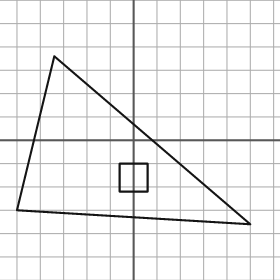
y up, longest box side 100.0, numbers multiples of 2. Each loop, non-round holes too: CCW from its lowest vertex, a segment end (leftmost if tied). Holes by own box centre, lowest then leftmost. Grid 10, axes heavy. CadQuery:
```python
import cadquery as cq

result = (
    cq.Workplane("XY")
    .moveTo(50.0, -36.0)
    .lineTo(-34.0, 36.0)
    .lineTo(-50.0, -30.0)
    .close()
    .moveTo(-6.0, -22.0)
    .lineTo(6.0, -22.0)
    .lineTo(6.0, -10.0)
    .lineTo(-6.0, -10.0)
    .close()
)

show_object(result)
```